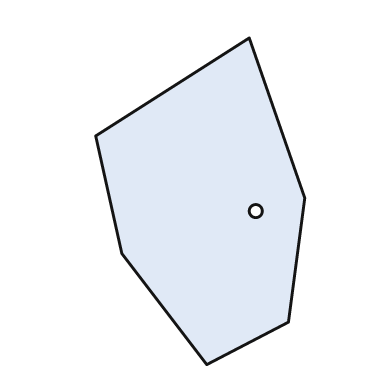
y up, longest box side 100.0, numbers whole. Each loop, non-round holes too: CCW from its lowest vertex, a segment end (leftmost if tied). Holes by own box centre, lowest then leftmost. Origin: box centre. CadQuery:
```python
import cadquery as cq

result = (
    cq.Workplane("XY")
    .moveTo(2.0, -50.0)
    .lineTo(27.0, -37.0)
    .lineTo(32.0, 1.0)
    .lineTo(15.0, 50.0)
    .lineTo(-32.0, 20.0)
    .lineTo(-24.0, -16.0)
    .close()
    .moveTo(17.0, -3.0)
    .circle(2.0)
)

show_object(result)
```